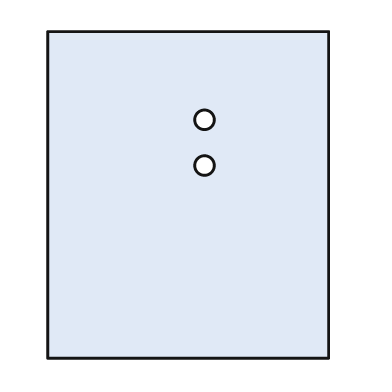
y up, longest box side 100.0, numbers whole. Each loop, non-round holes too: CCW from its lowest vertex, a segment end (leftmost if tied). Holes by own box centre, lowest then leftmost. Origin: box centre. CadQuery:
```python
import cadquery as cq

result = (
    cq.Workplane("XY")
    .moveTo(-43.0, -50.0)
    .lineTo(43.0, -50.0)
    .lineTo(43.0, 50.0)
    .lineTo(-43.0, 50.0)
    .close()
    .moveTo(5.0, 9.0)
    .circle(3.0)
    .moveTo(5.0, 23.0)
    .circle(3.0)
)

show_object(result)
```